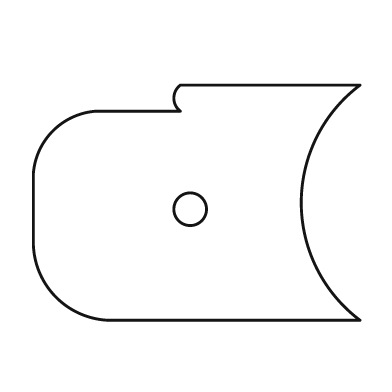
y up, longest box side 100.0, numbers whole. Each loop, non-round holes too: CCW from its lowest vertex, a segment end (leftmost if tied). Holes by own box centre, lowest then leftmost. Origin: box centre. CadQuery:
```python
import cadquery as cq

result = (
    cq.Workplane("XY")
    .moveTo(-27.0, -36.0)
    .lineTo(50.0, -36.0)
    .threePointArc((32.0, 0.0), (50.0, 36.0))
    .lineTo(-5.0, 36.0)
    .threePointArc((-7.0, 32.0), (-5.0, 28.0))
    .lineTo(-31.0, 28.0)
    .threePointArc((-44.0, 22.0), (-50.0, 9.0))
    .lineTo(-50.0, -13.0)
    .threePointArc((-43.0, -29.0), (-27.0, -36.0))
    .close()
    .moveTo(-2.0, -2.0)
    .circle(5.0)
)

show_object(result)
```